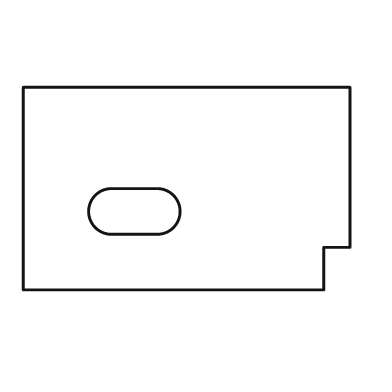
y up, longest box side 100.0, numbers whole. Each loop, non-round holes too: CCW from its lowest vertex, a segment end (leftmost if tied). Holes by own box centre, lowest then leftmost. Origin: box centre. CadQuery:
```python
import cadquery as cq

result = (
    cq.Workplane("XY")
    .moveTo(-50.0, -31.0)
    .lineTo(42.0, -31.0)
    .lineTo(42.0, -18.0)
    .lineTo(50.0, -18.0)
    .lineTo(50.0, 31.0)
    .lineTo(-50.0, 31.0)
    .close()
    .moveTo(-23.0, -14.0)
    .lineTo(-9.0, -14.0)
    .threePointArc((-2.0, -7.0), (-9.0, 0.0))
    .lineTo(-23.0, 0.0)
    .threePointArc((-30.0, -7.0), (-23.0, -14.0))
    .close()
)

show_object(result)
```